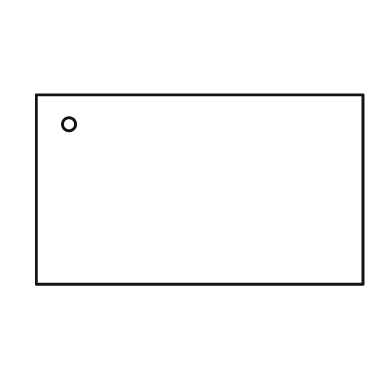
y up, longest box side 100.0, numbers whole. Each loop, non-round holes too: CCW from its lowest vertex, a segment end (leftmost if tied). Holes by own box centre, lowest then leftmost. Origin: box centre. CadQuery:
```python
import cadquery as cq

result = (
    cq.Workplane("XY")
    .moveTo(-50.0, -29.0)
    .lineTo(50.0, -29.0)
    .lineTo(50.0, 29.0)
    .lineTo(-50.0, 29.0)
    .close()
    .moveTo(-40.0, 20.0)
    .circle(2.0)
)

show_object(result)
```